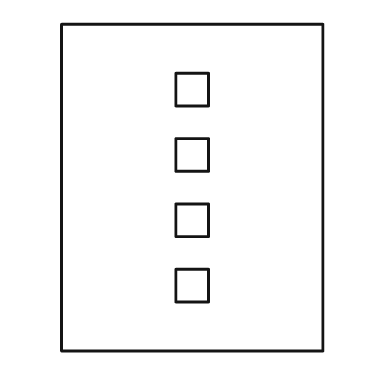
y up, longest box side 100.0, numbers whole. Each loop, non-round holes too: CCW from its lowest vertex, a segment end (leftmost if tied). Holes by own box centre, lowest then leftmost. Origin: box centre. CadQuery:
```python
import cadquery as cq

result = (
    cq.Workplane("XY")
    .moveTo(-40.0, -50.0)
    .lineTo(40.0, -50.0)
    .lineTo(40.0, 50.0)
    .lineTo(-40.0, 50.0)
    .close()
    .moveTo(-5.0, -35.0)
    .lineTo(5.0, -35.0)
    .lineTo(5.0, -25.0)
    .lineTo(-5.0, -25.0)
    .close()
    .moveTo(-5.0, -15.0)
    .lineTo(5.0, -15.0)
    .lineTo(5.0, -5.0)
    .lineTo(-5.0, -5.0)
    .close()
    .moveTo(-5.0, 5.0)
    .lineTo(5.0, 5.0)
    .lineTo(5.0, 15.0)
    .lineTo(-5.0, 15.0)
    .close()
    .moveTo(-5.0, 25.0)
    .lineTo(5.0, 25.0)
    .lineTo(5.0, 35.0)
    .lineTo(-5.0, 35.0)
    .close()
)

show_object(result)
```